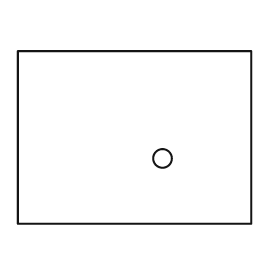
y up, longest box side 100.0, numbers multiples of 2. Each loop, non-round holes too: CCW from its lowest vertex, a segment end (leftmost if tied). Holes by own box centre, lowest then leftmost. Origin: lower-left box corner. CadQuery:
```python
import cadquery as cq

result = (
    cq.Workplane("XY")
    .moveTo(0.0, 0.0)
    .lineTo(100.0, 0.0)
    .lineTo(100.0, 74.0)
    .lineTo(0.0, 74.0)
    .close()
    .moveTo(62.0, 28.0)
    .circle(4.0)
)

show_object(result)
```